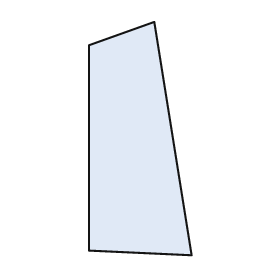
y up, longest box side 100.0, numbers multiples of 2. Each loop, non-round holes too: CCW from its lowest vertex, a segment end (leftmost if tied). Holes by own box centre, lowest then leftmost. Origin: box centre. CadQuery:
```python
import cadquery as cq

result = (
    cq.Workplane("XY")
    .moveTo(22.0, -50.0)
    .lineTo(6.0, 50.0)
    .lineTo(-22.0, 40.0)
    .lineTo(-22.0, -48.0)
    .close()
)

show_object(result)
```